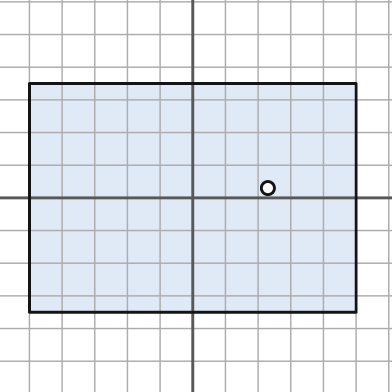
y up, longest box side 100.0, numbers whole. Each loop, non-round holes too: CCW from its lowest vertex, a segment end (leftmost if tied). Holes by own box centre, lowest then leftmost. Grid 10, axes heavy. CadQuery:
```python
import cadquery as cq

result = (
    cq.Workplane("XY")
    .moveTo(-50.0, -35.0)
    .lineTo(50.0, -35.0)
    .lineTo(50.0, 35.0)
    .lineTo(-50.0, 35.0)
    .close()
    .moveTo(23.0, 3.0)
    .circle(2.0)
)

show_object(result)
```